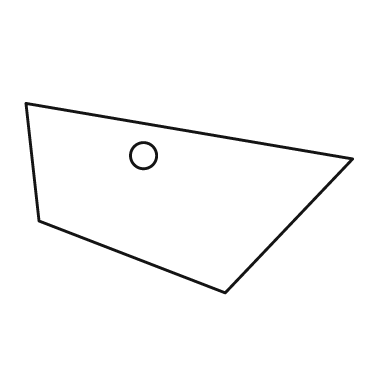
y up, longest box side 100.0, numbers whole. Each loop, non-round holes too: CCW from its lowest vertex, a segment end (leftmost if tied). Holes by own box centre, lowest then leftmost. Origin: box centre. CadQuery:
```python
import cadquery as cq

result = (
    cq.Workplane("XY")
    .moveTo(11.0, -29.0)
    .lineTo(50.0, 12.0)
    .lineTo(-50.0, 29.0)
    .lineTo(-46.0, -7.0)
    .close()
    .moveTo(-14.0, 13.0)
    .circle(4.0)
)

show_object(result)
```